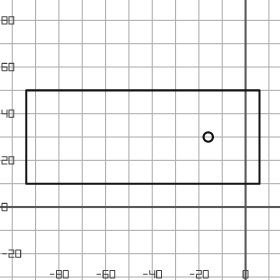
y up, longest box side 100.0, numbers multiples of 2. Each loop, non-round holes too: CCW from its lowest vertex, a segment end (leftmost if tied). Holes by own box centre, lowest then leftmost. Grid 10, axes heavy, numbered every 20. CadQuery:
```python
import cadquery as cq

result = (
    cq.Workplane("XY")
    .moveTo(-94.0, 10.0)
    .lineTo(6.0, 10.0)
    .lineTo(6.0, 50.0)
    .lineTo(-94.0, 50.0)
    .close()
    .moveTo(-16.0, 30.0)
    .circle(2.0)
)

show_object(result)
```